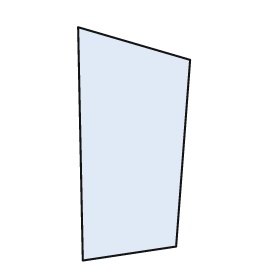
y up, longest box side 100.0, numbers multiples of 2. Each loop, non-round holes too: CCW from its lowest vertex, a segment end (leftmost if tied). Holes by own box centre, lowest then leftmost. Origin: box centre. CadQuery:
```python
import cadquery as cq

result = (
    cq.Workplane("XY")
    .moveTo(-22.0, -50.0)
    .lineTo(18.0, -44.0)
    .lineTo(24.0, 36.0)
    .lineTo(-24.0, 50.0)
    .close()
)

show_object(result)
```